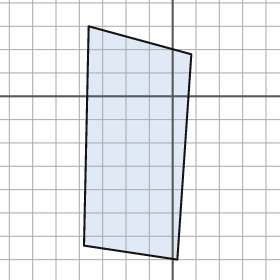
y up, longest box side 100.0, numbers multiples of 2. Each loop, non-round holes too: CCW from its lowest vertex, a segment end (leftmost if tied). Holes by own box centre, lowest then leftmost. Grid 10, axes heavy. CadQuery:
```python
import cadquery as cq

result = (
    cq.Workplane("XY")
    .moveTo(2.0, -70.0)
    .lineTo(8.0, 18.0)
    .lineTo(-36.0, 30.0)
    .lineTo(-38.0, -64.0)
    .close()
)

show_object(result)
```